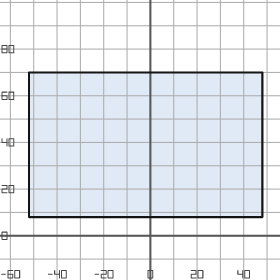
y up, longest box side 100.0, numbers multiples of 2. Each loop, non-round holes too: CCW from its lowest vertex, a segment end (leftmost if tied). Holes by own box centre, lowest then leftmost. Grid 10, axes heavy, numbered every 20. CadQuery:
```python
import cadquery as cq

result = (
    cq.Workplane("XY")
    .moveTo(-52.0, 8.0)
    .lineTo(48.0, 8.0)
    .lineTo(48.0, 70.0)
    .lineTo(-52.0, 70.0)
    .close()
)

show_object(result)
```